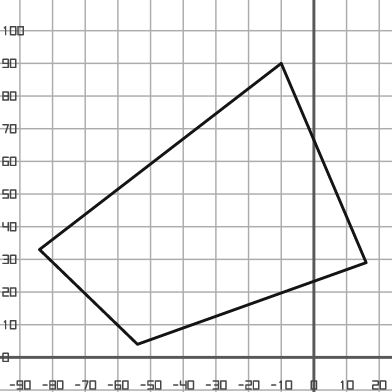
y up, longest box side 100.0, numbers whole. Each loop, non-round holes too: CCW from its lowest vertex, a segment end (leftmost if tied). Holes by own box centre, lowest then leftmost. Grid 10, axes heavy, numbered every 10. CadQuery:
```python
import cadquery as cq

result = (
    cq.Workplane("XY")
    .moveTo(-54.0, 4.0)
    .lineTo(16.0, 29.0)
    .lineTo(-10.0, 90.0)
    .lineTo(-84.0, 33.0)
    .close()
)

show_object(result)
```